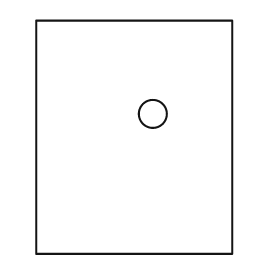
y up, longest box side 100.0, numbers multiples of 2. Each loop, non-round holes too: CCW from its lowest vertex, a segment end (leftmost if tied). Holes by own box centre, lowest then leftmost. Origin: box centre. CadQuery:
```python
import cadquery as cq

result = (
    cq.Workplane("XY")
    .moveTo(-42.0, -50.0)
    .lineTo(42.0, -50.0)
    .lineTo(42.0, 50.0)
    .lineTo(-42.0, 50.0)
    .close()
    .moveTo(8.0, 10.0)
    .circle(6.0)
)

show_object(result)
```